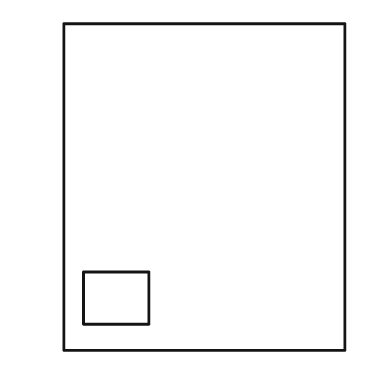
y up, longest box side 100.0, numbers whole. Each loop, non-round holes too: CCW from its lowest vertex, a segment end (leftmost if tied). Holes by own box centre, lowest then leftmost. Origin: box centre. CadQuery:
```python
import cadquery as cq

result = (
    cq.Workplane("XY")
    .moveTo(-43.0, -50.0)
    .lineTo(43.0, -50.0)
    .lineTo(43.0, 50.0)
    .lineTo(-43.0, 50.0)
    .close()
    .moveTo(-37.0, -42.0)
    .lineTo(-17.0, -42.0)
    .lineTo(-17.0, -26.0)
    .lineTo(-37.0, -26.0)
    .close()
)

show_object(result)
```